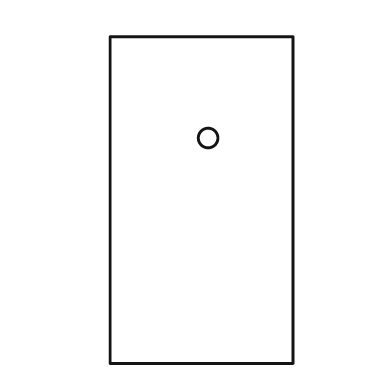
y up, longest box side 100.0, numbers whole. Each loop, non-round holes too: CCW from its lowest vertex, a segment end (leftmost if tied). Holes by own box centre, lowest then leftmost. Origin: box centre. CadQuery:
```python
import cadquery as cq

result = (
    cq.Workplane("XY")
    .moveTo(-28.0, -50.0)
    .lineTo(28.0, -50.0)
    .lineTo(28.0, 50.0)
    .lineTo(-28.0, 50.0)
    .close()
    .moveTo(2.0, 19.0)
    .circle(3.0)
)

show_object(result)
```